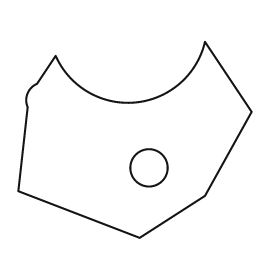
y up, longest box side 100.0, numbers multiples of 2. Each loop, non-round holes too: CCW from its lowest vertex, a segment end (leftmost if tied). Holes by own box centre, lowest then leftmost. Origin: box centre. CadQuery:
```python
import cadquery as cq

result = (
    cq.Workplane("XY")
    .moveTo(2.0, -42.0)
    .lineTo(30.0, -24.0)
    .lineTo(50.0, 12.0)
    .lineTo(30.0, 42.0)
    .threePointArc((0.0, 16.0), (-34.0, 36.0))
    .lineTo(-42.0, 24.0)
    .threePointArc((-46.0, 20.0), (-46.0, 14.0))
    .lineTo(-50.0, -22.0)
    .close()
    .moveTo(6.0, -12.0)
    .circle(8.0)
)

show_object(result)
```